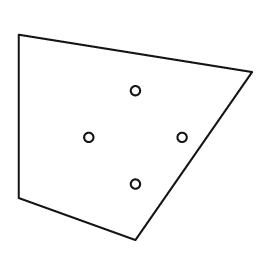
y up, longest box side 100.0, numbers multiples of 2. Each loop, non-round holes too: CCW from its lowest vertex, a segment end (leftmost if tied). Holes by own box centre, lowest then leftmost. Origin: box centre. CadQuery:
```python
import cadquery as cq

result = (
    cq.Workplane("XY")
    .moveTo(0.0, -44.0)
    .lineTo(50.0, 28.0)
    .lineTo(-50.0, 44.0)
    .lineTo(-50.0, -26.0)
    .close()
    .moveTo(0.0, -20.0)
    .circle(2.0)
    .moveTo(-20.0, 0.0)
    .circle(2.0)
    .moveTo(20.0, 0.0)
    .circle(2.0)
    .moveTo(0.0, 20.0)
    .circle(2.0)
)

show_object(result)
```